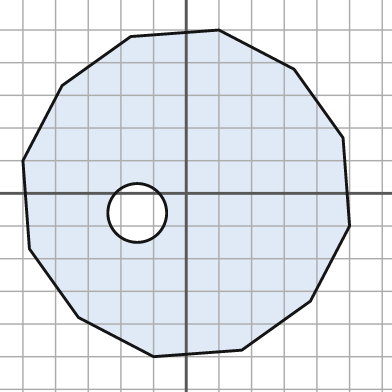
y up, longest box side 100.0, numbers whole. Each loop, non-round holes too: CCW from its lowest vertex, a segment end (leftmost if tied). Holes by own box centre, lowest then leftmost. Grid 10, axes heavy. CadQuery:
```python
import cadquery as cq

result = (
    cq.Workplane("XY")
    .moveTo(-10.0, -50.0)
    .lineTo(17.0, -48.0)
    .lineTo(38.0, -33.0)
    .lineTo(50.0, -10.0)
    .lineTo(48.0, 17.0)
    .lineTo(33.0, 38.0)
    .lineTo(10.0, 50.0)
    .lineTo(-17.0, 48.0)
    .lineTo(-38.0, 33.0)
    .lineTo(-50.0, 10.0)
    .lineTo(-48.0, -17.0)
    .lineTo(-33.0, -38.0)
    .close()
    .moveTo(-15.0, -6.0)
    .circle(9.0)
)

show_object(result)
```